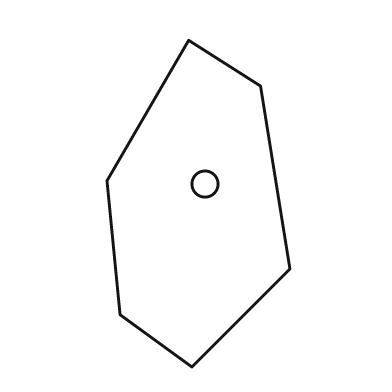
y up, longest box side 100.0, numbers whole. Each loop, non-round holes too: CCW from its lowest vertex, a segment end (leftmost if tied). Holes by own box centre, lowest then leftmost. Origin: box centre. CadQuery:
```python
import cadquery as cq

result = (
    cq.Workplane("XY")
    .moveTo(-2.0, -50.0)
    .lineTo(28.0, -20.0)
    .lineTo(19.0, 36.0)
    .lineTo(-3.0, 50.0)
    .lineTo(-28.0, 7.0)
    .lineTo(-24.0, -34.0)
    .close()
    .moveTo(2.0, 6.0)
    .circle(4.0)
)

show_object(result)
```